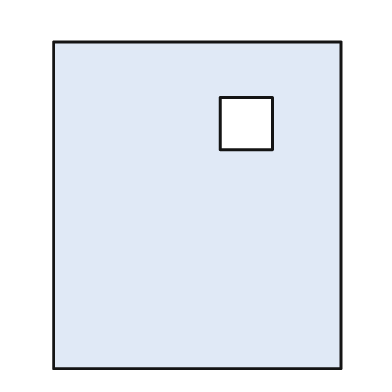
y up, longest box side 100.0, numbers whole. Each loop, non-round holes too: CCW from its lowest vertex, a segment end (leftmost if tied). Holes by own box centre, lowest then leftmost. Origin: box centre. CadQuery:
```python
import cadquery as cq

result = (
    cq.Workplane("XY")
    .moveTo(-44.0, -50.0)
    .lineTo(44.0, -50.0)
    .lineTo(44.0, 50.0)
    .lineTo(-44.0, 50.0)
    .close()
    .moveTo(7.0, 17.0)
    .lineTo(23.0, 17.0)
    .lineTo(23.0, 33.0)
    .lineTo(7.0, 33.0)
    .close()
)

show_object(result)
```